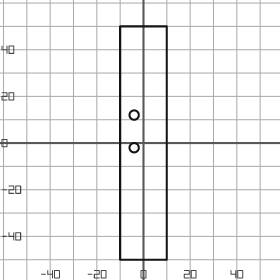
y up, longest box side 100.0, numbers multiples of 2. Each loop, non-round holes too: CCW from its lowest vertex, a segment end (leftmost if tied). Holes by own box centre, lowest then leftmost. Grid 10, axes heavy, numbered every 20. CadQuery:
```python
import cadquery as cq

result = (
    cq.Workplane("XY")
    .moveTo(-10.0, -50.0)
    .lineTo(10.0, -50.0)
    .lineTo(10.0, 50.0)
    .lineTo(-10.0, 50.0)
    .close()
    .moveTo(-4.0, -2.0)
    .circle(2.0)
    .moveTo(-4.0, 12.0)
    .circle(2.0)
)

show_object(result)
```